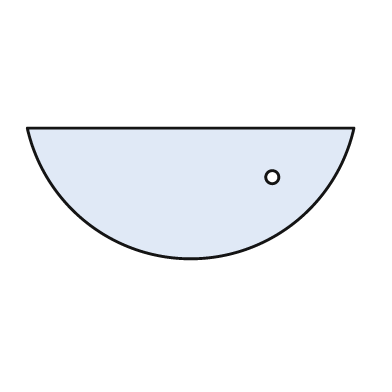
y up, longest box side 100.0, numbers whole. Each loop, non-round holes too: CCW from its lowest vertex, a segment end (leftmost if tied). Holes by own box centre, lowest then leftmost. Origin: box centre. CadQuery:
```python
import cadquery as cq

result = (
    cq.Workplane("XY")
    .moveTo(-50.0, 20.0)
    .threePointArc((0.0, -20.0), (50.0, 20.0))
    .close()
    .moveTo(25.0, 5.0)
    .circle(2.0)
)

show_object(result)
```